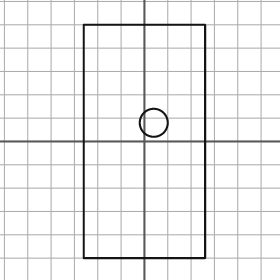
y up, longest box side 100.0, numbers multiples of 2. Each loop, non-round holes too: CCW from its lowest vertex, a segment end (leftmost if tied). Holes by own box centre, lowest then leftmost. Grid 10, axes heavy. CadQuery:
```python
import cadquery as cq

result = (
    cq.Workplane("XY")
    .moveTo(-26.0, -50.0)
    .lineTo(26.0, -50.0)
    .lineTo(26.0, 50.0)
    .lineTo(-26.0, 50.0)
    .close()
    .moveTo(4.0, 8.0)
    .circle(6.0)
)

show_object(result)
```